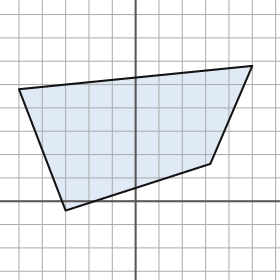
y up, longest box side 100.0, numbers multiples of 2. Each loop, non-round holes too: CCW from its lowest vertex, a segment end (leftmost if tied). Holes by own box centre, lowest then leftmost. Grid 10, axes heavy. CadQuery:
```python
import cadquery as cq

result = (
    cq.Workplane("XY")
    .moveTo(-30.0, -4.0)
    .lineTo(32.0, 16.0)
    .lineTo(50.0, 58.0)
    .lineTo(-50.0, 48.0)
    .close()
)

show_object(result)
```